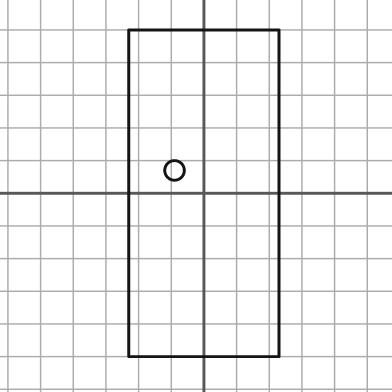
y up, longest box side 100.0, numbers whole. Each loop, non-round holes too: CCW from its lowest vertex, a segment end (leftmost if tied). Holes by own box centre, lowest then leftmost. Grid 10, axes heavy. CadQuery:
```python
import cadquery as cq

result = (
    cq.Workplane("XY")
    .moveTo(-23.0, -50.0)
    .lineTo(23.0, -50.0)
    .lineTo(23.0, 50.0)
    .lineTo(-23.0, 50.0)
    .close()
    .moveTo(-9.0, 7.0)
    .circle(3.0)
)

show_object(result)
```